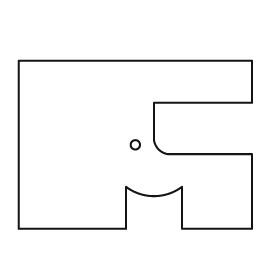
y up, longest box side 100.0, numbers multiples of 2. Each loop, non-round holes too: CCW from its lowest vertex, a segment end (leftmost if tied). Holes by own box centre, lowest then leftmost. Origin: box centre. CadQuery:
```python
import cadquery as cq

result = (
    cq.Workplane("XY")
    .moveTo(-50.0, -36.0)
    .lineTo(-4.0, -36.0)
    .lineTo(-4.0, -18.0)
    .threePointArc((8.0, -22.0), (20.0, -18.0))
    .lineTo(20.0, -36.0)
    .lineTo(50.0, -36.0)
    .lineTo(50.0, -4.0)
    .lineTo(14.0, -4.0)
    .threePointArc((10.0, -2.0), (8.0, 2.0))
    .lineTo(8.0, 18.0)
    .lineTo(50.0, 18.0)
    .lineTo(50.0, 36.0)
    .lineTo(-50.0, 36.0)
    .close()
    .moveTo(0.0, 0.0)
    .circle(2.0)
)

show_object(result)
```